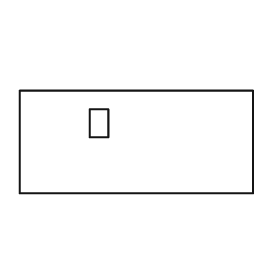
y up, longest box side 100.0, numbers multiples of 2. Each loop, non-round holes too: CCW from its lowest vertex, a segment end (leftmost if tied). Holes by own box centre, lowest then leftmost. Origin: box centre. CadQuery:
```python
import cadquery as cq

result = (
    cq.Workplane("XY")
    .moveTo(-50.0, -22.0)
    .lineTo(50.0, -22.0)
    .lineTo(50.0, 22.0)
    .lineTo(-50.0, 22.0)
    .close()
    .moveTo(-20.0, 2.0)
    .lineTo(-12.0, 2.0)
    .lineTo(-12.0, 14.0)
    .lineTo(-20.0, 14.0)
    .close()
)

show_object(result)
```